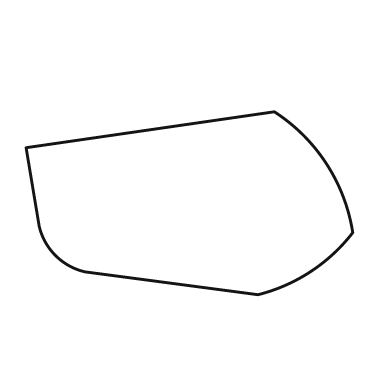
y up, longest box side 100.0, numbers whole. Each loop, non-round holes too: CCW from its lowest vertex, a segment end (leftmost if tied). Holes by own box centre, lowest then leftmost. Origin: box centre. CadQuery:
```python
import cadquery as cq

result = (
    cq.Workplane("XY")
    .moveTo(21.0, -28.0)
    .threePointArc((37.0, -21.0), (50.0, -9.0))
    .threePointArc((42.0, 12.0), (26.0, 28.0))
    .lineTo(-50.0, 17.0)
    .lineTo(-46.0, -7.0)
    .threePointArc((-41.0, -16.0), (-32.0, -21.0))
    .close()
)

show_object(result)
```